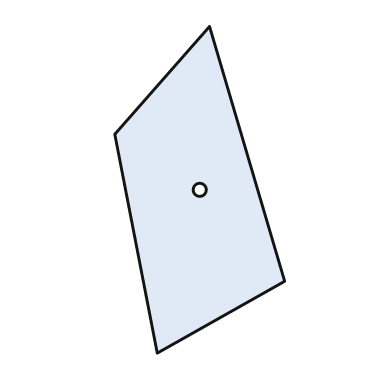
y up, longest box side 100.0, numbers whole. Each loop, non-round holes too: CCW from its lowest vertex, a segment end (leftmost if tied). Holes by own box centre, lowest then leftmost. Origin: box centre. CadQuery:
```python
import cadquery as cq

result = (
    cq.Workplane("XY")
    .moveTo(-13.0, -50.0)
    .lineTo(26.0, -28.0)
    .lineTo(3.0, 50.0)
    .lineTo(-26.0, 17.0)
    .close()
    .moveTo(0.0, 0.0)
    .circle(2.0)
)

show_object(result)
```